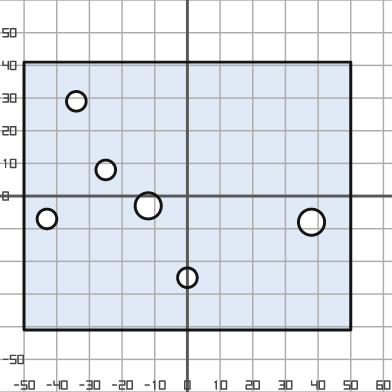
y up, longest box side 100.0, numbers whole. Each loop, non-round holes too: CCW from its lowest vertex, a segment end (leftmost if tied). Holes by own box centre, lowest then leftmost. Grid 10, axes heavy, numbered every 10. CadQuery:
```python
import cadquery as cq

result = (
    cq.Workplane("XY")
    .moveTo(-50.0, -41.0)
    .lineTo(50.0, -41.0)
    .lineTo(50.0, 41.0)
    .lineTo(-50.0, 41.0)
    .close()
    .moveTo(0.0, -25.0)
    .circle(3.0)
    .moveTo(38.0, -8.0)
    .circle(4.0)
    .moveTo(-43.0, -7.0)
    .circle(3.0)
    .moveTo(-12.0, -3.0)
    .circle(4.0)
    .moveTo(-25.0, 8.0)
    .circle(3.0)
    .moveTo(-34.0, 29.0)
    .circle(3.0)
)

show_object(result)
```